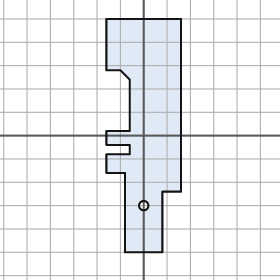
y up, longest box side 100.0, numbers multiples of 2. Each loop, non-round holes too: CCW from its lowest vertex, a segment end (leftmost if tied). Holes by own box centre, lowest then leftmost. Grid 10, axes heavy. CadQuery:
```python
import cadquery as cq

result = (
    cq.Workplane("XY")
    .moveTo(-8.0, -50.0)
    .lineTo(8.0, -50.0)
    .lineTo(8.0, -24.0)
    .lineTo(16.0, -24.0)
    .lineTo(16.0, 50.0)
    .lineTo(-16.0, 50.0)
    .lineTo(-16.0, 28.0)
    .lineTo(-10.0, 28.0)
    .lineTo(-6.0, 24.0)
    .lineTo(-6.0, 2.0)
    .lineTo(-16.0, 2.0)
    .lineTo(-16.0, -4.0)
    .lineTo(-6.0, -4.0)
    .lineTo(-6.0, -8.0)
    .lineTo(-16.0, -8.0)
    .lineTo(-16.0, -16.0)
    .lineTo(-8.0, -16.0)
    .close()
    .moveTo(0.0, -30.0)
    .circle(2.0)
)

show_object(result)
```